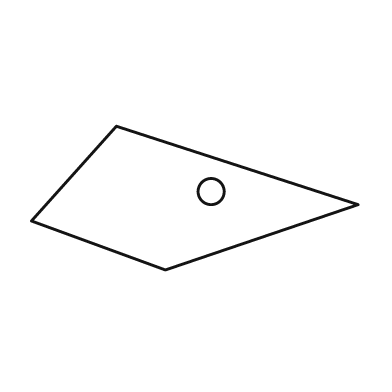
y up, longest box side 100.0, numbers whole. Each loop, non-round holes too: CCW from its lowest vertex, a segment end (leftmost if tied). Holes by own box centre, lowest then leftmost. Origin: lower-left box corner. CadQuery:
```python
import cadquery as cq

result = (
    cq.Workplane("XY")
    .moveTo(41.0, 0.0)
    .lineTo(100.0, 20.0)
    .lineTo(26.0, 44.0)
    .lineTo(0.0, 15.0)
    .close()
    .moveTo(55.0, 24.0)
    .circle(4.0)
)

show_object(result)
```